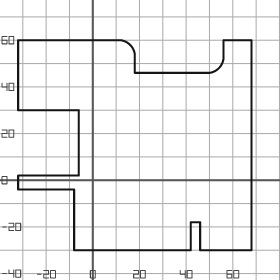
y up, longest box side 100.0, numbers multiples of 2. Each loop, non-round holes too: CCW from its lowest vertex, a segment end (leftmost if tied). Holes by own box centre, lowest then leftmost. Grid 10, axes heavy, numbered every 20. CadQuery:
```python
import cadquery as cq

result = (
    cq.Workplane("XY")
    .moveTo(-8.0, -30.0)
    .lineTo(42.0, -30.0)
    .lineTo(42.0, -18.0)
    .lineTo(46.0, -18.0)
    .lineTo(46.0, -30.0)
    .lineTo(68.0, -30.0)
    .lineTo(68.0, 60.0)
    .lineTo(56.0, 60.0)
    .lineTo(56.0, 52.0)
    .threePointArc((54.0, 48.0), (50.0, 46.0))
    .lineTo(18.0, 46.0)
    .lineTo(18.0, 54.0)
    .threePointArc((16.0, 58.0), (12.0, 60.0))
    .lineTo(-32.0, 60.0)
    .lineTo(-32.0, 30.0)
    .lineTo(-6.0, 30.0)
    .lineTo(-6.0, 2.0)
    .lineTo(-32.0, 2.0)
    .lineTo(-32.0, -4.0)
    .lineTo(-8.0, -4.0)
    .close()
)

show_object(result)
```